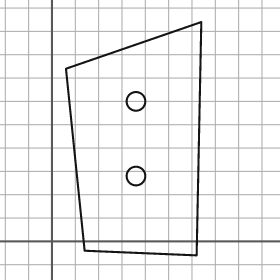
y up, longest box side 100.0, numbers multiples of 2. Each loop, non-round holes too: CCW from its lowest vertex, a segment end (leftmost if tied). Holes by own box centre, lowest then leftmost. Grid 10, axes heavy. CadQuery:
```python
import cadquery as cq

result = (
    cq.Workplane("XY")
    .moveTo(62.0, -6.0)
    .lineTo(64.0, 94.0)
    .lineTo(6.0, 74.0)
    .lineTo(14.0, -4.0)
    .close()
    .moveTo(36.0, 28.0)
    .circle(4.0)
    .moveTo(36.0, 60.0)
    .circle(4.0)
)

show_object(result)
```